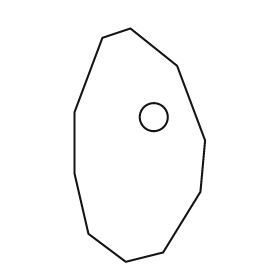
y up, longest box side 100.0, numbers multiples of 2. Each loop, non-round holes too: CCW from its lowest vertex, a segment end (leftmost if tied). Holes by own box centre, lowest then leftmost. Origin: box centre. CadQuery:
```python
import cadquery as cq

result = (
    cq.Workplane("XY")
    .moveTo(-6.0, -50.0)
    .lineTo(10.0, -46.0)
    .lineTo(26.0, -20.0)
    .lineTo(28.0, 2.0)
    .lineTo(16.0, 34.0)
    .lineTo(-4.0, 50.0)
    .lineTo(-16.0, 46.0)
    .lineTo(-28.0, 14.0)
    .lineTo(-28.0, -12.0)
    .lineTo(-22.0, -38.0)
    .close()
    .moveTo(6.0, 12.0)
    .circle(6.0)
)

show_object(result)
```